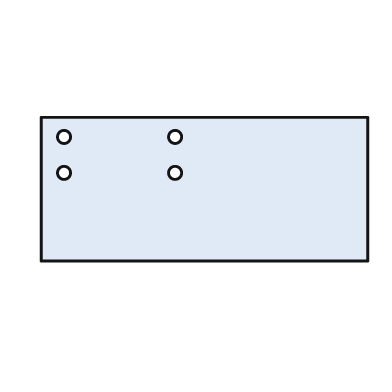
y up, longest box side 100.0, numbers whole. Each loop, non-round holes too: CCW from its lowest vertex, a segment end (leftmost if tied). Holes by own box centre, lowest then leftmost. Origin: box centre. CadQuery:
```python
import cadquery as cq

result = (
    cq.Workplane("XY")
    .moveTo(-50.0, -22.0)
    .lineTo(50.0, -22.0)
    .lineTo(50.0, 22.0)
    .lineTo(-50.0, 22.0)
    .close()
    .moveTo(-43.0, 5.0)
    .circle(2.0)
    .moveTo(-9.0, 5.0)
    .circle(2.0)
    .moveTo(-43.0, 16.0)
    .circle(2.0)
    .moveTo(-9.0, 16.0)
    .circle(2.0)
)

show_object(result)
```